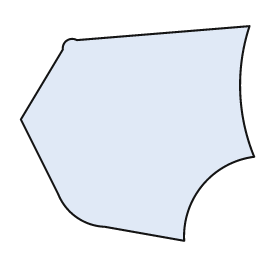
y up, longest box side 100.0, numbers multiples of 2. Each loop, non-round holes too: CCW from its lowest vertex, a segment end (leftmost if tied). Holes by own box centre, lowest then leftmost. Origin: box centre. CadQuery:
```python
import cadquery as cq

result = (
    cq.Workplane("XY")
    .moveTo(20.0, -46.0)
    .threePointArc((28.0, -22.0), (50.0, -10.0))
    .threePointArc((44.0, 18.0), (48.0, 46.0))
    .lineTo(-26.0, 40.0)
    .threePointArc((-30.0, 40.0), (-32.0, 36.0))
    .lineTo(-50.0, 6.0)
    .lineTo(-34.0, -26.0)
    .threePointArc((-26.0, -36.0), (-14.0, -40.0))
    .close()
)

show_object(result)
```